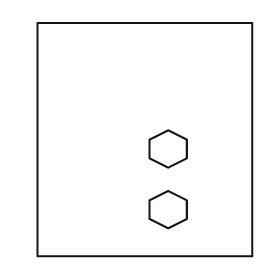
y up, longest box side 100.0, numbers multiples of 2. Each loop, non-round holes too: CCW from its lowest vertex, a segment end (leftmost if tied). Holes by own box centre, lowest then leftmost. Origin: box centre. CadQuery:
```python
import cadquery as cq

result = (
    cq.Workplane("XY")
    .moveTo(-46.0, -50.0)
    .lineTo(46.0, -50.0)
    .lineTo(46.0, 50.0)
    .lineTo(-46.0, 50.0)
    .close()
    .moveTo(10.0, -38.0)
    .lineTo(18.0, -34.0)
    .lineTo(18.0, -26.0)
    .lineTo(10.0, -22.0)
    .lineTo(2.0, -26.0)
    .lineTo(2.0, -34.0)
    .close()
    .moveTo(10.0, -12.0)
    .lineTo(18.0, -8.0)
    .lineTo(18.0, 0.0)
    .lineTo(10.0, 4.0)
    .lineTo(2.0, 0.0)
    .lineTo(2.0, -8.0)
    .close()
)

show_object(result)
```